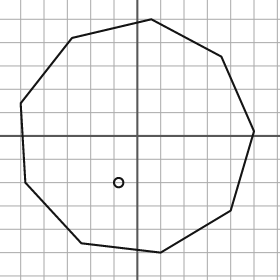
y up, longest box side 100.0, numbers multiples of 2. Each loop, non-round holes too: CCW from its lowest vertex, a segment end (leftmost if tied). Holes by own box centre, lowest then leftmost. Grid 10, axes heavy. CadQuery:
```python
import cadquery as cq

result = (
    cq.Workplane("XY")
    .moveTo(10.0, -50.0)
    .lineTo(40.0, -32.0)
    .lineTo(50.0, 2.0)
    .lineTo(36.0, 34.0)
    .lineTo(6.0, 50.0)
    .lineTo(-28.0, 42.0)
    .lineTo(-50.0, 14.0)
    .lineTo(-48.0, -20.0)
    .lineTo(-24.0, -46.0)
    .close()
    .moveTo(-8.0, -20.0)
    .circle(2.0)
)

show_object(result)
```